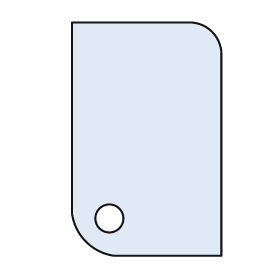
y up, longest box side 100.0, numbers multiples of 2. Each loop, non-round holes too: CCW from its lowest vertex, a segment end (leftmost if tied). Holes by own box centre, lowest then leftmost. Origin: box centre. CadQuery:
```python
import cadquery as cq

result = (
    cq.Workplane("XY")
    .moveTo(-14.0, -50.0)
    .lineTo(32.0, -50.0)
    .lineTo(32.0, 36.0)
    .threePointArc((28.0, 46.0), (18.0, 50.0))
    .lineTo(-32.0, 50.0)
    .lineTo(-32.0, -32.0)
    .threePointArc((-26.0, -44.0), (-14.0, -50.0))
    .close()
    .moveTo(-16.0, -34.0)
    .circle(6.0)
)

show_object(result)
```